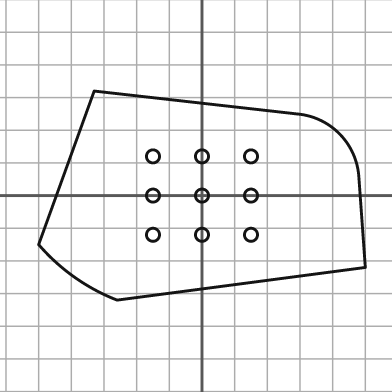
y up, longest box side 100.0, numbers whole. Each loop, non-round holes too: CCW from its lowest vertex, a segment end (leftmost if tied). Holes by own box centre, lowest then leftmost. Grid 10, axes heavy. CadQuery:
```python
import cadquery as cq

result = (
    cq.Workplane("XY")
    .moveTo(-26.0, -32.0)
    .lineTo(50.0, -22.0)
    .lineTo(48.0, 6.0)
    .threePointArc((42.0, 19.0), (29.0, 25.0))
    .lineTo(-33.0, 32.0)
    .lineTo(-50.0, -15.0)
    .threePointArc((-39.0, -25.0), (-26.0, -32.0))
    .close()
    .moveTo(-15.0, -12.0)
    .circle(2.0)
    .moveTo(0.0, -12.0)
    .circle(2.0)
    .moveTo(15.0, -12.0)
    .circle(2.0)
    .moveTo(-15.0, 0.0)
    .circle(2.0)
    .moveTo(0.0, 0.0)
    .circle(2.0)
    .moveTo(15.0, 0.0)
    .circle(2.0)
    .moveTo(-15.0, 12.0)
    .circle(2.0)
    .moveTo(0.0, 12.0)
    .circle(2.0)
    .moveTo(15.0, 12.0)
    .circle(2.0)
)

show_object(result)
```